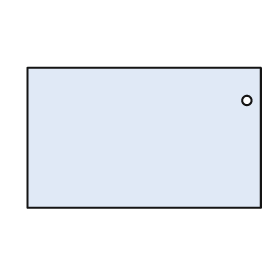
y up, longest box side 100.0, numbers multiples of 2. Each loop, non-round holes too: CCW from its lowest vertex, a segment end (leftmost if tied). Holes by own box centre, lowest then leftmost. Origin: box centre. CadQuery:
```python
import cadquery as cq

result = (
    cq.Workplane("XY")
    .moveTo(-50.0, -30.0)
    .lineTo(50.0, -30.0)
    .lineTo(50.0, 30.0)
    .lineTo(-50.0, 30.0)
    .close()
    .moveTo(44.0, 16.0)
    .circle(2.0)
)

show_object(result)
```